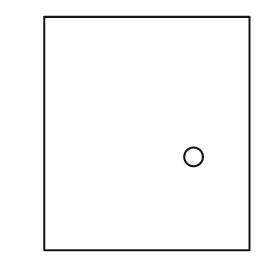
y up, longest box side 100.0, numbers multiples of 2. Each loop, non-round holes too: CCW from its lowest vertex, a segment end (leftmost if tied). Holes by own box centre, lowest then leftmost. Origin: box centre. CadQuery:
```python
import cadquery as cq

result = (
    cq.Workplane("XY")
    .moveTo(-44.0, -50.0)
    .lineTo(44.0, -50.0)
    .lineTo(44.0, 50.0)
    .lineTo(-44.0, 50.0)
    .close()
    .moveTo(20.0, -10.0)
    .circle(4.0)
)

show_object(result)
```